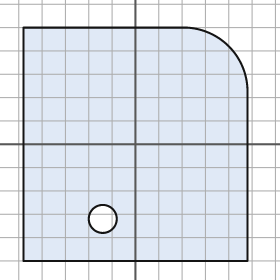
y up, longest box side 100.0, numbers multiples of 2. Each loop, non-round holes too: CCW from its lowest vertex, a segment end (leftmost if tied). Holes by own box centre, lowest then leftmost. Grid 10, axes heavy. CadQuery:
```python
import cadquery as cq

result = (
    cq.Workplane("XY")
    .moveTo(-48.0, -50.0)
    .lineTo(48.0, -50.0)
    .lineTo(48.0, 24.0)
    .threePointArc((40.0, 42.0), (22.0, 50.0))
    .lineTo(-48.0, 50.0)
    .close()
    .moveTo(-14.0, -32.0)
    .circle(6.0)
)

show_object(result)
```